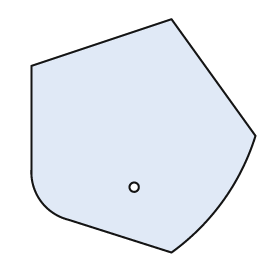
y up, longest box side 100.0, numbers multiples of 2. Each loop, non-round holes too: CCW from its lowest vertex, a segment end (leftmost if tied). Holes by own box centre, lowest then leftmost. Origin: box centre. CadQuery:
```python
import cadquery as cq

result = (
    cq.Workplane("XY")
    .moveTo(12.0, -50.0)
    .threePointArc((34.0, -28.0), (48.0, 0.0))
    .lineTo(12.0, 50.0)
    .lineTo(-48.0, 30.0)
    .lineTo(-48.0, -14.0)
    .threePointArc((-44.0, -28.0), (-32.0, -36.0))
    .close()
    .moveTo(-4.0, -22.0)
    .circle(2.0)
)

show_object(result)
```